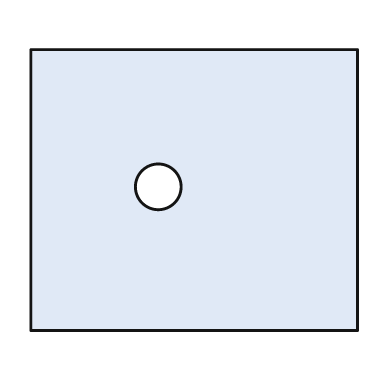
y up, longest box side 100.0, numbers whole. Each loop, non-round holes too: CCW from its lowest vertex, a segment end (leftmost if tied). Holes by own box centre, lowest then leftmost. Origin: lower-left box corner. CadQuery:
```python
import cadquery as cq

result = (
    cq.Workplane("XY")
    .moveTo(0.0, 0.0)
    .lineTo(100.0, 0.0)
    .lineTo(100.0, 86.0)
    .lineTo(0.0, 86.0)
    .close()
    .moveTo(39.0, 44.0)
    .circle(7.0)
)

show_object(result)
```